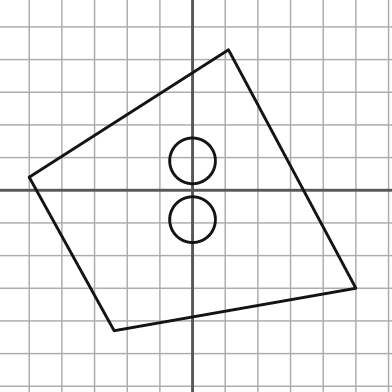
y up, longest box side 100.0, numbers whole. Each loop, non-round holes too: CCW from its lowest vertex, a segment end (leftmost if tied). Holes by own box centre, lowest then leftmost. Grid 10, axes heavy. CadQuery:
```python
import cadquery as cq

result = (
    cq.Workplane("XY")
    .moveTo(-24.0, -43.0)
    .lineTo(50.0, -30.0)
    .lineTo(11.0, 43.0)
    .lineTo(-50.0, 4.0)
    .close()
    .moveTo(0.0, -9.0)
    .circle(7.0)
    .moveTo(0.0, 9.0)
    .circle(7.0)
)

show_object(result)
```